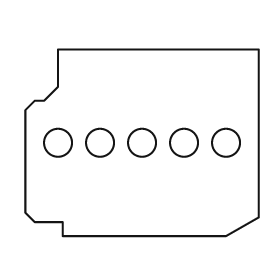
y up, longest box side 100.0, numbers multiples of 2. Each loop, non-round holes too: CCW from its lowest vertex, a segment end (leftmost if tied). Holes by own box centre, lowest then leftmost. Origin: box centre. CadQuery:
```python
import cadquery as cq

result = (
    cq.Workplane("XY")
    .moveTo(-34.0, -40.0)
    .lineTo(36.0, -40.0)
    .lineTo(50.0, -32.0)
    .lineTo(50.0, 40.0)
    .lineTo(-36.0, 40.0)
    .lineTo(-36.0, 24.0)
    .lineTo(-42.0, 18.0)
    .lineTo(-46.0, 18.0)
    .lineTo(-50.0, 14.0)
    .lineTo(-50.0, -30.0)
    .lineTo(-46.0, -34.0)
    .lineTo(-34.0, -34.0)
    .close()
    .moveTo(-36.0, 0.0)
    .circle(6.0)
    .moveTo(-18.0, 0.0)
    .circle(6.0)
    .moveTo(0.0, 0.0)
    .circle(6.0)
    .moveTo(18.0, 0.0)
    .circle(6.0)
    .moveTo(36.0, 0.0)
    .circle(6.0)
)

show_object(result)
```